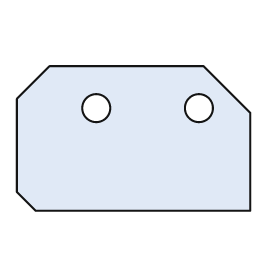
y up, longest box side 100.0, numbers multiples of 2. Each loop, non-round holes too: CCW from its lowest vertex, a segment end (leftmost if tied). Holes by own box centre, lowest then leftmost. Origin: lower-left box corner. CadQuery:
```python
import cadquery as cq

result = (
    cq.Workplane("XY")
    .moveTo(8.0, 0.0)
    .lineTo(100.0, 0.0)
    .lineTo(100.0, 42.0)
    .lineTo(80.0, 62.0)
    .lineTo(14.0, 62.0)
    .lineTo(0.0, 48.0)
    .lineTo(0.0, 8.0)
    .close()
    .moveTo(34.0, 44.0)
    .circle(6.0)
    .moveTo(78.0, 44.0)
    .circle(6.0)
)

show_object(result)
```